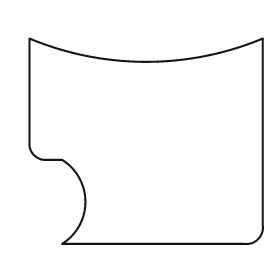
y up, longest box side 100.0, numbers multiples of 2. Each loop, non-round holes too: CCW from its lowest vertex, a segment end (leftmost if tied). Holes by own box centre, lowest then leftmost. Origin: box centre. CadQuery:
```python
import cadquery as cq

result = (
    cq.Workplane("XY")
    .moveTo(-36.0, -44.0)
    .lineTo(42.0, -44.0)
    .threePointArc((48.0, -42.0), (50.0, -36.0))
    .lineTo(50.0, 44.0)
    .threePointArc((0.0, 34.0), (-50.0, 44.0))
    .lineTo(-50.0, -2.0)
    .threePointArc((-48.0, -6.0), (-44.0, -8.0))
    .lineTo(-36.0, -8.0)
    .threePointArc((-26.0, -26.0), (-36.0, -44.0))
    .close()
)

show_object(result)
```